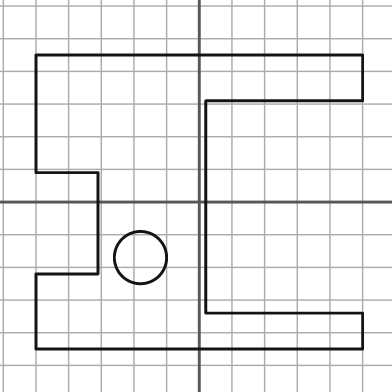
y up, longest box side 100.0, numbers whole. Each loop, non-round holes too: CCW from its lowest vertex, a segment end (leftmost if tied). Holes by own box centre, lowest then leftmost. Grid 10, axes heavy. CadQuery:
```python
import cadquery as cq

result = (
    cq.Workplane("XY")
    .moveTo(-50.0, -45.0)
    .lineTo(50.0, -45.0)
    .lineTo(50.0, -34.0)
    .lineTo(2.0, -34.0)
    .lineTo(2.0, 31.0)
    .lineTo(50.0, 31.0)
    .lineTo(50.0, 45.0)
    .lineTo(-50.0, 45.0)
    .lineTo(-50.0, 9.0)
    .lineTo(-31.0, 9.0)
    .lineTo(-31.0, -22.0)
    .lineTo(-50.0, -22.0)
    .close()
    .moveTo(-18.0, -17.0)
    .circle(8.0)
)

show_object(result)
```